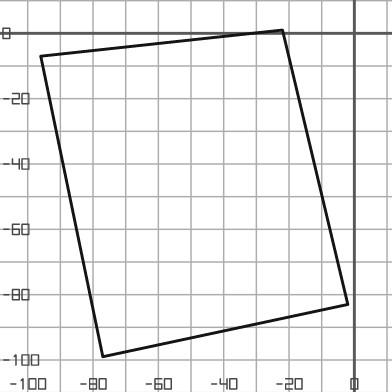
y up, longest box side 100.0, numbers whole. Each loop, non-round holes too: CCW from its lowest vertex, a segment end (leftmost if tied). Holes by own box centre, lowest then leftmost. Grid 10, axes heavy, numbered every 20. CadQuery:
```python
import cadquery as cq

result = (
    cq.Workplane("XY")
    .moveTo(-77.0, -99.0)
    .lineTo(-2.0, -83.0)
    .lineTo(-22.0, 1.0)
    .lineTo(-96.0, -7.0)
    .close()
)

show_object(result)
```